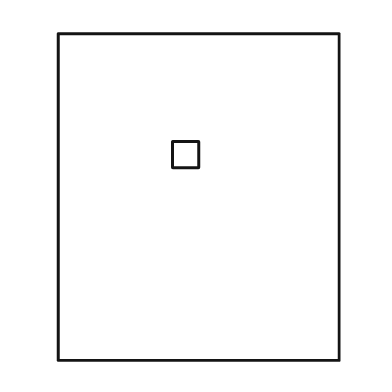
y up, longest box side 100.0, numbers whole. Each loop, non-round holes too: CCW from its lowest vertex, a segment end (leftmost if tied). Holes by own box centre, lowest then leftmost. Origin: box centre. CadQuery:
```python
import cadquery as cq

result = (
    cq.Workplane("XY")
    .moveTo(-43.0, -50.0)
    .lineTo(43.0, -50.0)
    .lineTo(43.0, 50.0)
    .lineTo(-43.0, 50.0)
    .close()
    .moveTo(-8.0, 9.0)
    .lineTo(0.0, 9.0)
    .lineTo(0.0, 17.0)
    .lineTo(-8.0, 17.0)
    .close()
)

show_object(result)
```